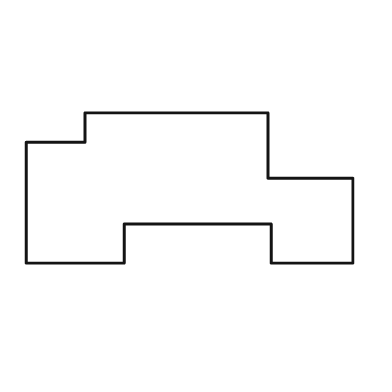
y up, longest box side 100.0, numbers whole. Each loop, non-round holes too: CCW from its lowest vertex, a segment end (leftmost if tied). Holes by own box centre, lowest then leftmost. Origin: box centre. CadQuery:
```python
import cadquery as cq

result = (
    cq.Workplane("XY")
    .moveTo(-50.0, -23.0)
    .lineTo(-20.0, -23.0)
    .lineTo(-20.0, -11.0)
    .lineTo(25.0, -11.0)
    .lineTo(25.0, -23.0)
    .lineTo(50.0, -23.0)
    .lineTo(50.0, 3.0)
    .lineTo(24.0, 3.0)
    .lineTo(24.0, 23.0)
    .lineTo(-32.0, 23.0)
    .lineTo(-32.0, 14.0)
    .lineTo(-50.0, 14.0)
    .close()
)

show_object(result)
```